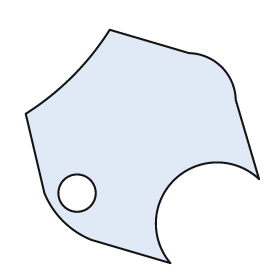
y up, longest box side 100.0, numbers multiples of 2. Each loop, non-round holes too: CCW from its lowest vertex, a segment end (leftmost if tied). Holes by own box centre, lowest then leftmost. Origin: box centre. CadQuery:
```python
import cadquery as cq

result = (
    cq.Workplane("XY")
    .moveTo(12.0, -50.0)
    .threePointArc((14.0, -14.0), (50.0, -14.0))
    .lineTo(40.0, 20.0)
    .threePointArc((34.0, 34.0), (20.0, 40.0))
    .lineTo(-14.0, 50.0)
    .threePointArc((-30.0, 30.0), (-50.0, 14.0))
    .lineTo(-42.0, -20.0)
    .threePointArc((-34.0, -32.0), (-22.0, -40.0))
    .close()
    .moveTo(-28.0, -20.0)
    .circle(8.0)
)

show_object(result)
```